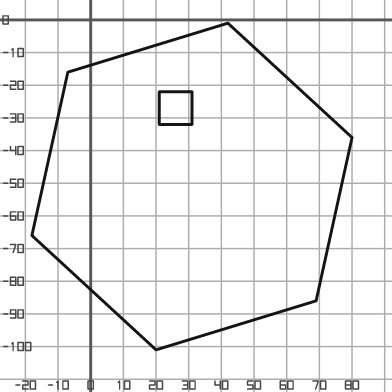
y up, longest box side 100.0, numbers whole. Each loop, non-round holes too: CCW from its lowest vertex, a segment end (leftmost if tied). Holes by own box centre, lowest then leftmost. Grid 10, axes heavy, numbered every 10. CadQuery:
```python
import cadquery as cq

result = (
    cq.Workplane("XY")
    .moveTo(20.0, -101.0)
    .lineTo(69.0, -86.0)
    .lineTo(80.0, -36.0)
    .lineTo(42.0, -1.0)
    .lineTo(-7.0, -16.0)
    .lineTo(-18.0, -66.0)
    .close()
    .moveTo(21.0, -32.0)
    .lineTo(31.0, -32.0)
    .lineTo(31.0, -22.0)
    .lineTo(21.0, -22.0)
    .close()
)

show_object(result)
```